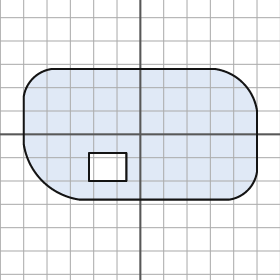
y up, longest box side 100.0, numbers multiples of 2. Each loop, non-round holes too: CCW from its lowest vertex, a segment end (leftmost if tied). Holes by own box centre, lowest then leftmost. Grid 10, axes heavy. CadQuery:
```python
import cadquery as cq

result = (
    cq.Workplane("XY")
    .moveTo(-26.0, -28.0)
    .lineTo(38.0, -28.0)
    .threePointArc((46.0, -24.0), (50.0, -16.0))
    .lineTo(50.0, 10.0)
    .threePointArc((44.0, 22.0), (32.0, 28.0))
    .lineTo(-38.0, 28.0)
    .threePointArc((-46.0, 24.0), (-50.0, 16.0))
    .lineTo(-50.0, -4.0)
    .threePointArc((-42.0, -20.0), (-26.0, -28.0))
    .close()
    .moveTo(-22.0, -20.0)
    .lineTo(-6.0, -20.0)
    .lineTo(-6.0, -8.0)
    .lineTo(-22.0, -8.0)
    .close()
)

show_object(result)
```